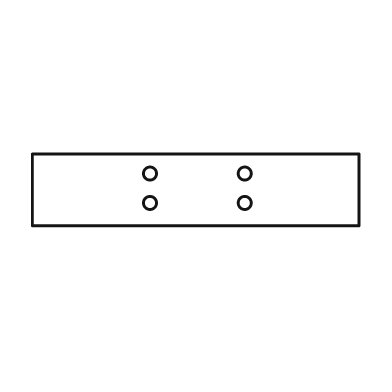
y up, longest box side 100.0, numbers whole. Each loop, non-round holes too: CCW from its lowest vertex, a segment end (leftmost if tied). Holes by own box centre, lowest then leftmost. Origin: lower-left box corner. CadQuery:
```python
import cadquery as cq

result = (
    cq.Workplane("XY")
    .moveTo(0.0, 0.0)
    .lineTo(100.0, 0.0)
    .lineTo(100.0, 22.0)
    .lineTo(0.0, 22.0)
    .close()
    .moveTo(36.0, 7.0)
    .circle(2.0)
    .moveTo(65.0, 7.0)
    .circle(2.0)
    .moveTo(36.0, 16.0)
    .circle(2.0)
    .moveTo(65.0, 16.0)
    .circle(2.0)
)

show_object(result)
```